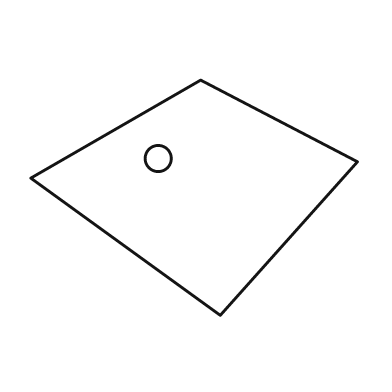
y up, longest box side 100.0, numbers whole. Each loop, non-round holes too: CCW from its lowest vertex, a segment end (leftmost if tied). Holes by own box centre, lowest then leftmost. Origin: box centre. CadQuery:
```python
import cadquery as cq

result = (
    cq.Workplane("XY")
    .moveTo(8.0, -36.0)
    .lineTo(50.0, 11.0)
    .lineTo(2.0, 36.0)
    .lineTo(-50.0, 6.0)
    .close()
    .moveTo(-11.0, 12.0)
    .circle(4.0)
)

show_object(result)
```